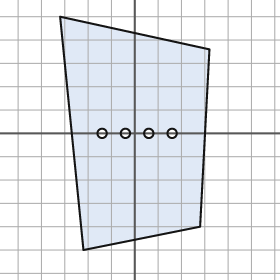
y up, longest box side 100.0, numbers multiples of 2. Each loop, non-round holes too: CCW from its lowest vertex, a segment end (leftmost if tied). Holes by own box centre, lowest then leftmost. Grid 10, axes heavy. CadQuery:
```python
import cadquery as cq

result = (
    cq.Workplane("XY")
    .moveTo(-22.0, -50.0)
    .lineTo(28.0, -40.0)
    .lineTo(32.0, 36.0)
    .lineTo(-32.0, 50.0)
    .close()
    .moveTo(-14.0, 0.0)
    .circle(2.0)
    .moveTo(-4.0, 0.0)
    .circle(2.0)
    .moveTo(6.0, 0.0)
    .circle(2.0)
    .moveTo(16.0, 0.0)
    .circle(2.0)
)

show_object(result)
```